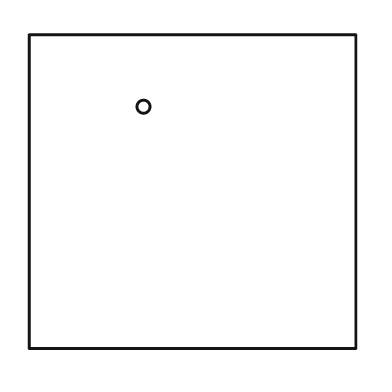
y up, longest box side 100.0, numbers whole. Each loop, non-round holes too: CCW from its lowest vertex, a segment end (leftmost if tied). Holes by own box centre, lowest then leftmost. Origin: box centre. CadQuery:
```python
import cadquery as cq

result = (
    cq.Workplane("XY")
    .moveTo(-50.0, -48.0)
    .lineTo(50.0, -48.0)
    .lineTo(50.0, 48.0)
    .lineTo(-50.0, 48.0)
    .close()
    .moveTo(-15.0, 26.0)
    .circle(2.0)
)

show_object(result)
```